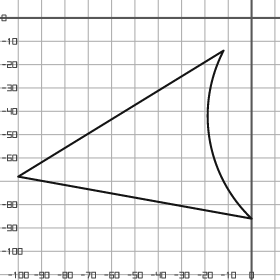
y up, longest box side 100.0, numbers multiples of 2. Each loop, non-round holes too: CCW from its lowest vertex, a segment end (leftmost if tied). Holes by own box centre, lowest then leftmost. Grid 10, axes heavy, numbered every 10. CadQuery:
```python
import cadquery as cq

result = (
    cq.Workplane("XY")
    .moveTo(0.0, -86.0)
    .threePointArc((-18.0, -52.0), (-12.0, -14.0))
    .lineTo(-100.0, -68.0)
    .close()
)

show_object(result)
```